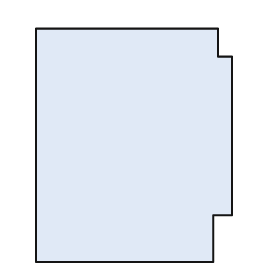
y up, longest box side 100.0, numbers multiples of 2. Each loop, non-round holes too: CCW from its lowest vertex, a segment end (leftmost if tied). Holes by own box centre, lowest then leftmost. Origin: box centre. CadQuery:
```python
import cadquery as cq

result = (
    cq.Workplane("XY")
    .moveTo(-42.0, -50.0)
    .lineTo(34.0, -50.0)
    .lineTo(34.0, -30.0)
    .lineTo(42.0, -30.0)
    .lineTo(42.0, 38.0)
    .lineTo(36.0, 38.0)
    .lineTo(36.0, 50.0)
    .lineTo(-42.0, 50.0)
    .close()
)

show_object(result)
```